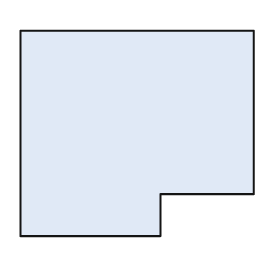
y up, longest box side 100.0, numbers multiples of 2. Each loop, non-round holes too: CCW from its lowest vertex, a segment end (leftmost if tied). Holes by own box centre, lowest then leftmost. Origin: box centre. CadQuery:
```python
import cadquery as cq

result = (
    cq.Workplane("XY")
    .moveTo(-50.0, -44.0)
    .lineTo(10.0, -44.0)
    .lineTo(10.0, -26.0)
    .lineTo(50.0, -26.0)
    .lineTo(50.0, 44.0)
    .lineTo(-50.0, 44.0)
    .close()
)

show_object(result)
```